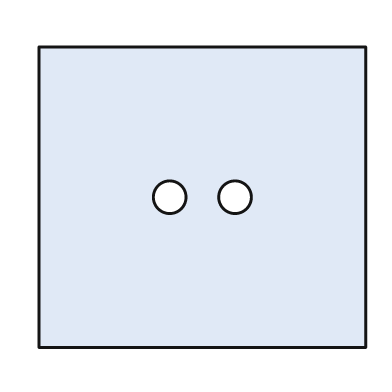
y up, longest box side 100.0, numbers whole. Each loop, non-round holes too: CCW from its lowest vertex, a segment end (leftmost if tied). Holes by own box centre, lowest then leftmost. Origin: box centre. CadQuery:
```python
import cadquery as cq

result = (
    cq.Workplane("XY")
    .moveTo(-50.0, -46.0)
    .lineTo(50.0, -46.0)
    .lineTo(50.0, 46.0)
    .lineTo(-50.0, 46.0)
    .close()
    .moveTo(-10.0, 0.0)
    .circle(5.0)
    .moveTo(10.0, 0.0)
    .circle(5.0)
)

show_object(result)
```